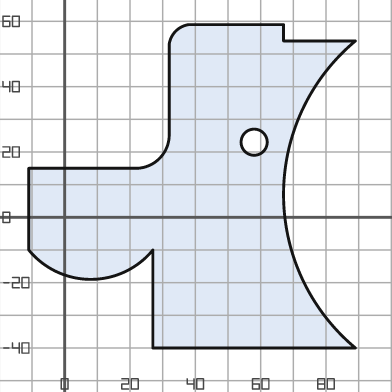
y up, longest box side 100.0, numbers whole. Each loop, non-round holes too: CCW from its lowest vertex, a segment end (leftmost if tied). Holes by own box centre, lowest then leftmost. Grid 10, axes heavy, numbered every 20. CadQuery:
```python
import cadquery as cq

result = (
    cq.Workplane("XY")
    .moveTo(27.0, -40.0)
    .lineTo(89.0, -40.0)
    .threePointArc((67.0, 7.0), (89.0, 54.0))
    .lineTo(67.0, 54.0)
    .lineTo(67.0, 59.0)
    .lineTo(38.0, 59.0)
    .threePointArc((34.0, 57.0), (32.0, 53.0))
    .lineTo(32.0, 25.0)
    .threePointArc((29.0, 18.0), (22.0, 15.0))
    .lineTo(-11.0, 15.0)
    .lineTo(-11.0, -10.0)
    .threePointArc((8.0, -19.0), (27.0, -10.0))
    .close()
    .moveTo(58.0, 23.0)
    .circle(4.0)
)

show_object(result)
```